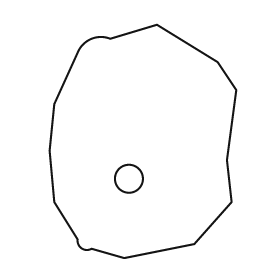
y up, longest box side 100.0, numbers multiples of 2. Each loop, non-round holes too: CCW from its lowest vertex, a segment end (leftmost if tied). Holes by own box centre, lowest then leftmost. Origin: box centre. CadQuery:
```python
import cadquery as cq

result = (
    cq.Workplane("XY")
    .moveTo(-8.0, -50.0)
    .lineTo(22.0, -44.0)
    .lineTo(38.0, -26.0)
    .lineTo(36.0, -8.0)
    .lineTo(40.0, 22.0)
    .lineTo(32.0, 34.0)
    .lineTo(6.0, 50.0)
    .lineTo(-14.0, 44.0)
    .threePointArc((-22.0, 44.0), (-28.0, 38.0))
    .lineTo(-38.0, 16.0)
    .lineTo(-40.0, -4.0)
    .lineTo(-38.0, -26.0)
    .lineTo(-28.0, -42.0)
    .threePointArc((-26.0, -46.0), (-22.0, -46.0))
    .close()
    .moveTo(-6.0, -16.0)
    .circle(6.0)
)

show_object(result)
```